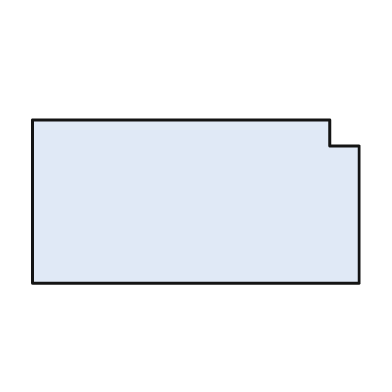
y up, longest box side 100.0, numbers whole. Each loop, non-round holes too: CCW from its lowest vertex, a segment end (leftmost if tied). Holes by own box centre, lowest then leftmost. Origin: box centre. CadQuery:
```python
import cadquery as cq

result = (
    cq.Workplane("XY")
    .moveTo(-50.0, -25.0)
    .lineTo(50.0, -25.0)
    .lineTo(50.0, 17.0)
    .lineTo(41.0, 17.0)
    .lineTo(41.0, 25.0)
    .lineTo(-50.0, 25.0)
    .close()
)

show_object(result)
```